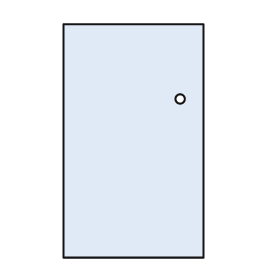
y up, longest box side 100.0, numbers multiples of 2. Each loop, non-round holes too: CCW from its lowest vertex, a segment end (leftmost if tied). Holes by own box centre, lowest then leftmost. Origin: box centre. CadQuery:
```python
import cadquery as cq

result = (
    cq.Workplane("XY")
    .moveTo(-30.0, -50.0)
    .lineTo(30.0, -50.0)
    .lineTo(30.0, 50.0)
    .lineTo(-30.0, 50.0)
    .close()
    .moveTo(20.0, 18.0)
    .circle(2.0)
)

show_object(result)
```